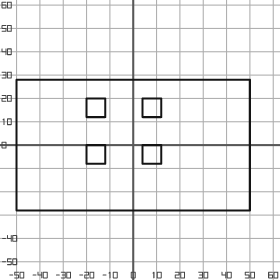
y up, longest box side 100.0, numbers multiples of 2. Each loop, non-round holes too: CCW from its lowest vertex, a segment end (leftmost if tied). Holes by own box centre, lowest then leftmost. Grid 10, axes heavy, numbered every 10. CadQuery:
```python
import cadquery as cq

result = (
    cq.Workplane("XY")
    .moveTo(-50.0, -28.0)
    .lineTo(50.0, -28.0)
    .lineTo(50.0, 28.0)
    .lineTo(-50.0, 28.0)
    .close()
    .moveTo(-20.0, -8.0)
    .lineTo(-12.0, -8.0)
    .lineTo(-12.0, 0.0)
    .lineTo(-20.0, 0.0)
    .close()
    .moveTo(4.0, -8.0)
    .lineTo(12.0, -8.0)
    .lineTo(12.0, 0.0)
    .lineTo(4.0, 0.0)
    .close()
    .moveTo(-20.0, 12.0)
    .lineTo(-12.0, 12.0)
    .lineTo(-12.0, 20.0)
    .lineTo(-20.0, 20.0)
    .close()
    .moveTo(4.0, 12.0)
    .lineTo(12.0, 12.0)
    .lineTo(12.0, 20.0)
    .lineTo(4.0, 20.0)
    .close()
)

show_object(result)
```